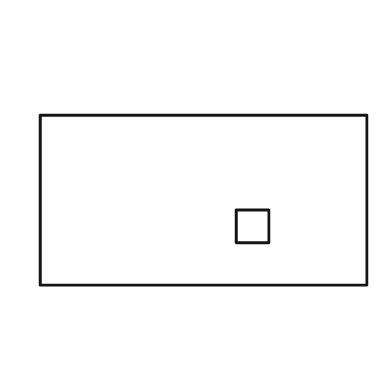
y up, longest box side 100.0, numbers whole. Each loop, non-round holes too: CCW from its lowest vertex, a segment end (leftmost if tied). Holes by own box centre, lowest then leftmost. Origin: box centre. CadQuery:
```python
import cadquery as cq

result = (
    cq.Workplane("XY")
    .moveTo(-50.0, -26.0)
    .lineTo(50.0, -26.0)
    .lineTo(50.0, 26.0)
    .lineTo(-50.0, 26.0)
    .close()
    .moveTo(10.0, -13.0)
    .lineTo(20.0, -13.0)
    .lineTo(20.0, -3.0)
    .lineTo(10.0, -3.0)
    .close()
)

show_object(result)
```